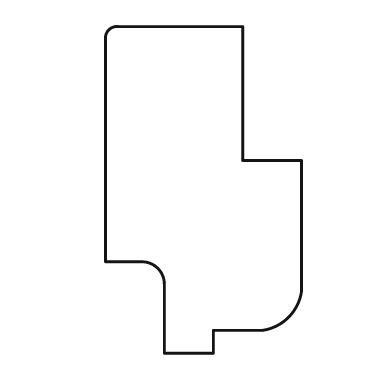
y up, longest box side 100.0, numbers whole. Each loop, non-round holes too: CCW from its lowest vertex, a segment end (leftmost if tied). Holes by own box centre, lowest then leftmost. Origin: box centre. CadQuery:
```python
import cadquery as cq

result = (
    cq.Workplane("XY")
    .moveTo(-12.0, -50.0)
    .lineTo(3.0, -50.0)
    .lineTo(3.0, -43.0)
    .lineTo(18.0, -43.0)
    .threePointArc((26.0, -39.0), (30.0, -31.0))
    .lineTo(30.0, 9.0)
    .lineTo(12.0, 9.0)
    .lineTo(12.0, 50.0)
    .lineTo(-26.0, 50.0)
    .threePointArc((-29.0, 49.0), (-30.0, 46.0))
    .lineTo(-30.0, -22.0)
    .lineTo(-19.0, -22.0)
    .threePointArc((-14.0, -24.0), (-12.0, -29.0))
    .close()
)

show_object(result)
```